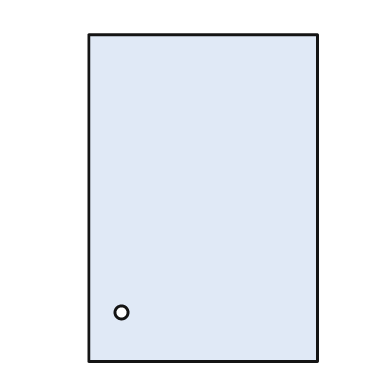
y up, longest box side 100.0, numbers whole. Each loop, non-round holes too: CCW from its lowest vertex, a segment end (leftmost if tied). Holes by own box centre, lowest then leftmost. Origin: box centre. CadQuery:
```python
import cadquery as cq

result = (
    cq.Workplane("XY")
    .moveTo(-35.0, -50.0)
    .lineTo(35.0, -50.0)
    .lineTo(35.0, 50.0)
    .lineTo(-35.0, 50.0)
    .close()
    .moveTo(-25.0, -35.0)
    .circle(2.0)
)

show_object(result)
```